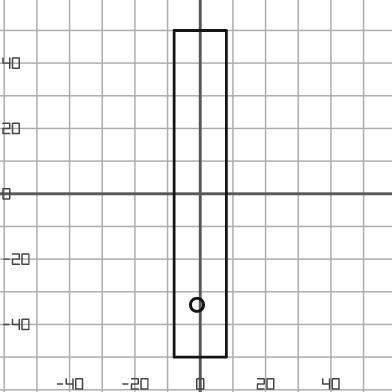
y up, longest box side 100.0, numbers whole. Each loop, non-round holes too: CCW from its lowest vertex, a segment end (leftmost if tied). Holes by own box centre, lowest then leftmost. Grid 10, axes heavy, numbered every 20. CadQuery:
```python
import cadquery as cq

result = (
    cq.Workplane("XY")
    .moveTo(-8.0, -50.0)
    .lineTo(8.0, -50.0)
    .lineTo(8.0, 50.0)
    .lineTo(-8.0, 50.0)
    .close()
    .moveTo(-1.0, -34.0)
    .circle(2.0)
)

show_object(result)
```